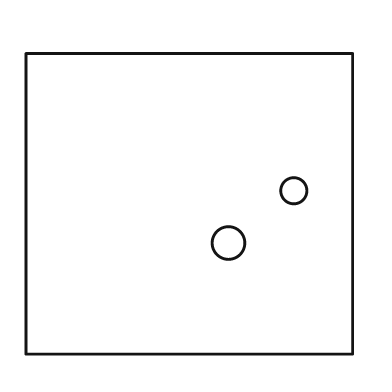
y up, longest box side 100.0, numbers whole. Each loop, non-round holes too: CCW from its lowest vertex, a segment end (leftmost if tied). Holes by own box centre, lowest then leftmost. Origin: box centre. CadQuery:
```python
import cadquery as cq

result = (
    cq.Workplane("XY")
    .moveTo(-50.0, -46.0)
    .lineTo(50.0, -46.0)
    .lineTo(50.0, 46.0)
    .lineTo(-50.0, 46.0)
    .close()
    .moveTo(12.0, -12.0)
    .circle(5.0)
    .moveTo(32.0, 4.0)
    .circle(4.0)
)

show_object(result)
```